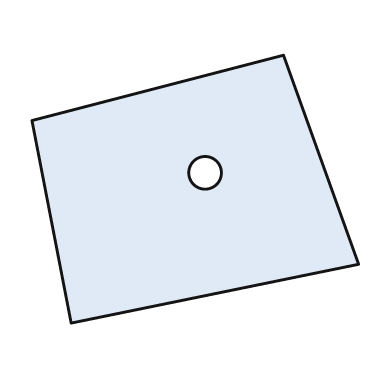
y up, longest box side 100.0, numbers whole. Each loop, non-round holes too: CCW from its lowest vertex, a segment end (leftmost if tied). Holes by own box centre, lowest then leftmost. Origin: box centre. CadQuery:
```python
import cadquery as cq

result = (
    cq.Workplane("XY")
    .moveTo(-38.0, -41.0)
    .lineTo(50.0, -23.0)
    .lineTo(27.0, 41.0)
    .lineTo(-50.0, 21.0)
    .close()
    .moveTo(3.0, 5.0)
    .circle(5.0)
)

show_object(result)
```